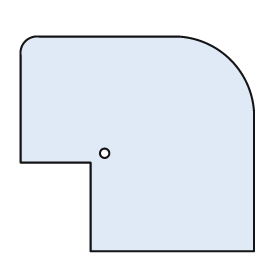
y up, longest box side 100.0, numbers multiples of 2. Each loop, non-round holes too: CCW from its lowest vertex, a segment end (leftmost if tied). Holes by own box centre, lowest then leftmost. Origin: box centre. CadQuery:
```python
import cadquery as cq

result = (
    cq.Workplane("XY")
    .moveTo(-20.0, -46.0)
    .lineTo(50.0, -46.0)
    .lineTo(50.0, 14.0)
    .threePointArc((40.0, 36.0), (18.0, 46.0))
    .lineTo(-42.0, 46.0)
    .threePointArc((-48.0, 44.0), (-50.0, 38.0))
    .lineTo(-50.0, -8.0)
    .lineTo(-20.0, -8.0)
    .close()
    .moveTo(-14.0, -4.0)
    .circle(2.0)
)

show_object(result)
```